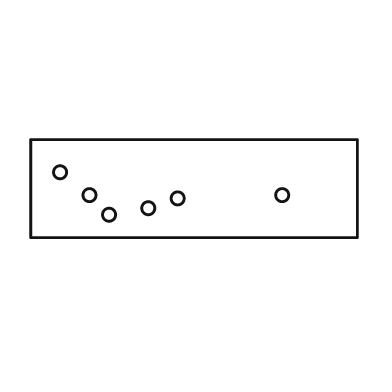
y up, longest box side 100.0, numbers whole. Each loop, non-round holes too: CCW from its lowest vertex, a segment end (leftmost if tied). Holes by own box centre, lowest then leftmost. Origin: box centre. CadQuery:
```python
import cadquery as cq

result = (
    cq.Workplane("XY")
    .moveTo(-50.0, -15.0)
    .lineTo(50.0, -15.0)
    .lineTo(50.0, 15.0)
    .lineTo(-50.0, 15.0)
    .close()
    .moveTo(-26.0, -8.0)
    .circle(2.0)
    .moveTo(-14.0, -6.0)
    .circle(2.0)
    .moveTo(-5.0, -3.0)
    .circle(2.0)
    .moveTo(-32.0, -2.0)
    .circle(2.0)
    .moveTo(27.0, -2.0)
    .circle(2.0)
    .moveTo(-41.0, 5.0)
    .circle(2.0)
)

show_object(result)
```